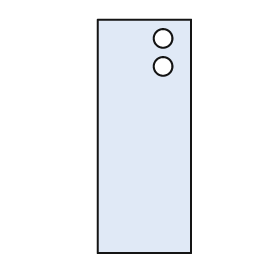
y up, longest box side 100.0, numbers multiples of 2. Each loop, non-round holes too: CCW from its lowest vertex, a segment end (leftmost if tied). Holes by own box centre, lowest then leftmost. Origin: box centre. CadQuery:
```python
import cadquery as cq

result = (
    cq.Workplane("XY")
    .moveTo(-20.0, -50.0)
    .lineTo(20.0, -50.0)
    .lineTo(20.0, 50.0)
    .lineTo(-20.0, 50.0)
    .close()
    .moveTo(8.0, 30.0)
    .circle(4.0)
    .moveTo(8.0, 42.0)
    .circle(4.0)
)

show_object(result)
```